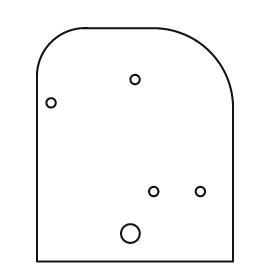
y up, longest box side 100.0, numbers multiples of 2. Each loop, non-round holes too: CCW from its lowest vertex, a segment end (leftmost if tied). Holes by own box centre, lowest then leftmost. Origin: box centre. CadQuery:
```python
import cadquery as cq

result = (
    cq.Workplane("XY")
    .moveTo(-42.0, -50.0)
    .lineTo(42.0, -50.0)
    .lineTo(42.0, 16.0)
    .threePointArc((32.0, 40.0), (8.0, 50.0))
    .lineTo(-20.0, 50.0)
    .threePointArc((-36.0, 44.0), (-42.0, 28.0))
    .close()
    .moveTo(-2.0, -38.0)
    .circle(4.0)
    .moveTo(8.0, -20.0)
    .circle(2.0)
    .moveTo(28.0, -20.0)
    .circle(2.0)
    .moveTo(-36.0, 18.0)
    .circle(2.0)
    .moveTo(0.0, 28.0)
    .circle(2.0)
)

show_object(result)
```